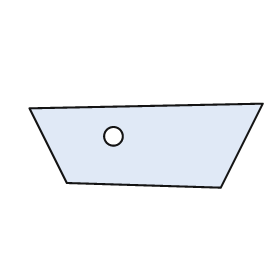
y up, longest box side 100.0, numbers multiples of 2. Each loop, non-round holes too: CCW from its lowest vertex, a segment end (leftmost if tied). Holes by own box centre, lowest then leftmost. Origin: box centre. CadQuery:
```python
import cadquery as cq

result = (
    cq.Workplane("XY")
    .moveTo(32.0, -18.0)
    .lineTo(50.0, 18.0)
    .lineTo(-50.0, 16.0)
    .lineTo(-34.0, -16.0)
    .close()
    .moveTo(-14.0, 4.0)
    .circle(4.0)
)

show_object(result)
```